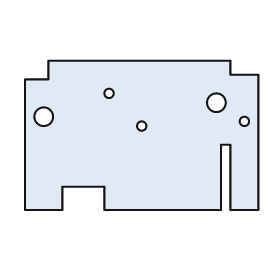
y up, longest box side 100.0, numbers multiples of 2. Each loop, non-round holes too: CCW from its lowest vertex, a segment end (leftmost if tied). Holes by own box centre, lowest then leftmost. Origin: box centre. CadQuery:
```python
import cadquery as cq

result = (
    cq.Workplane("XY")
    .moveTo(-50.0, -32.0)
    .lineTo(-34.0, -32.0)
    .lineTo(-34.0, -22.0)
    .lineTo(-16.0, -22.0)
    .lineTo(-16.0, -32.0)
    .lineTo(34.0, -32.0)
    .lineTo(34.0, -4.0)
    .lineTo(38.0, -4.0)
    .lineTo(38.0, -32.0)
    .lineTo(50.0, -32.0)
    .lineTo(50.0, 26.0)
    .lineTo(38.0, 26.0)
    .lineTo(38.0, 32.0)
    .lineTo(-40.0, 32.0)
    .lineTo(-40.0, 24.0)
    .lineTo(-50.0, 24.0)
    .close()
    .moveTo(0.0, 4.0)
    .circle(2.0)
    .moveTo(44.0, 6.0)
    .circle(2.0)
    .moveTo(-42.0, 8.0)
    .circle(4.0)
    .moveTo(32.0, 14.0)
    .circle(4.0)
    .moveTo(-14.0, 18.0)
    .circle(2.0)
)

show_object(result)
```